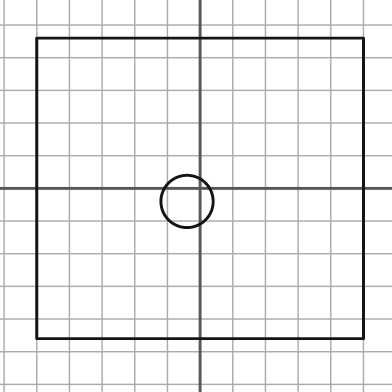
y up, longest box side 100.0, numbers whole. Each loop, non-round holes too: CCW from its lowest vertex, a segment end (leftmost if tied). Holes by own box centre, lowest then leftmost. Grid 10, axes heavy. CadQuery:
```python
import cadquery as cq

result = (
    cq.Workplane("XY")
    .moveTo(-50.0, -46.0)
    .lineTo(50.0, -46.0)
    .lineTo(50.0, 46.0)
    .lineTo(-50.0, 46.0)
    .close()
    .moveTo(-4.0, -4.0)
    .circle(8.0)
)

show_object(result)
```